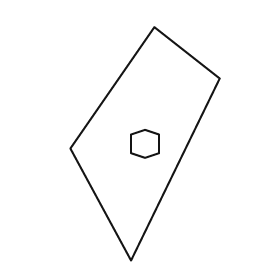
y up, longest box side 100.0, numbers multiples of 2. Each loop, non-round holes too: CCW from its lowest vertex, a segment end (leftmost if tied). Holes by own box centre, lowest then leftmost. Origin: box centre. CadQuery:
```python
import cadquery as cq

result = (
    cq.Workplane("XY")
    .moveTo(-6.0, -50.0)
    .lineTo(32.0, 28.0)
    .lineTo(4.0, 50.0)
    .lineTo(-32.0, -2.0)
    .close()
    .moveTo(0.0, -6.0)
    .lineTo(6.0, -4.0)
    .lineTo(6.0, 4.0)
    .lineTo(0.0, 6.0)
    .lineTo(-6.0, 4.0)
    .lineTo(-6.0, -4.0)
    .close()
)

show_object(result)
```